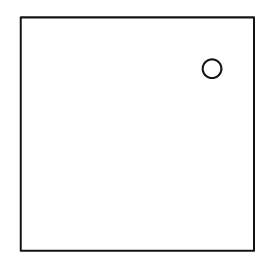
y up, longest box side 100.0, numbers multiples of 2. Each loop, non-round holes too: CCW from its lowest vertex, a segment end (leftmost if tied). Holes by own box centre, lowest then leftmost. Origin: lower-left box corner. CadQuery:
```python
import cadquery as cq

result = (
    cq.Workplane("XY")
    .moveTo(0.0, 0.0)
    .lineTo(100.0, 0.0)
    .lineTo(100.0, 100.0)
    .lineTo(0.0, 100.0)
    .close()
    .moveTo(82.0, 78.0)
    .circle(4.0)
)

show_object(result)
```